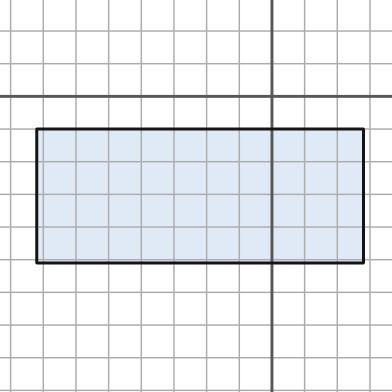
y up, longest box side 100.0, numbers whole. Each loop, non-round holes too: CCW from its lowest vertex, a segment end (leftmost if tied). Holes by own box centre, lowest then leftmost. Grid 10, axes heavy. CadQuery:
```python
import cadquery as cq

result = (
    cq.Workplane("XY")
    .moveTo(-72.0, -51.0)
    .lineTo(28.0, -51.0)
    .lineTo(28.0, -10.0)
    .lineTo(-72.0, -10.0)
    .close()
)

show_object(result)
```